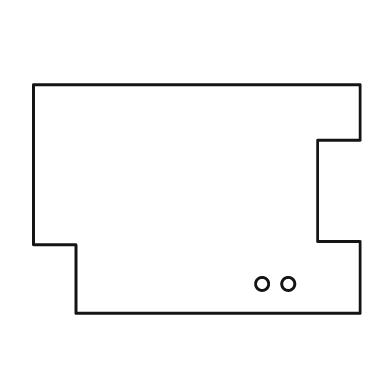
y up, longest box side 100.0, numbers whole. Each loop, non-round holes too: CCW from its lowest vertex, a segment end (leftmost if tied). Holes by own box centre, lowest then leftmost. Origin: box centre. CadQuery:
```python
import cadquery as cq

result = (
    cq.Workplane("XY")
    .moveTo(-37.0, -35.0)
    .lineTo(50.0, -35.0)
    .lineTo(50.0, -13.0)
    .lineTo(37.0, -13.0)
    .lineTo(37.0, 18.0)
    .lineTo(50.0, 18.0)
    .lineTo(50.0, 35.0)
    .lineTo(-50.0, 35.0)
    .lineTo(-50.0, -14.0)
    .lineTo(-37.0, -14.0)
    .close()
    .moveTo(20.0, -26.0)
    .circle(2.0)
    .moveTo(28.0, -26.0)
    .circle(2.0)
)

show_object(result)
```